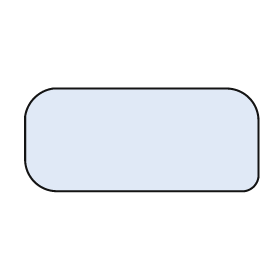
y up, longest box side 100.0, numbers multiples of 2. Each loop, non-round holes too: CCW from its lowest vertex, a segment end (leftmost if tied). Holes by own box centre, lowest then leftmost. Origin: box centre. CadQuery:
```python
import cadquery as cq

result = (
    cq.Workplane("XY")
    .moveTo(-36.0, -22.0)
    .lineTo(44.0, -22.0)
    .threePointArc((48.0, -20.0), (50.0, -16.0))
    .lineTo(50.0, 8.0)
    .threePointArc((46.0, 18.0), (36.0, 22.0))
    .lineTo(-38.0, 22.0)
    .threePointArc((-46.0, 18.0), (-50.0, 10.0))
    .lineTo(-50.0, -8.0)
    .threePointArc((-46.0, -18.0), (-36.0, -22.0))
    .close()
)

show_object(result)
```